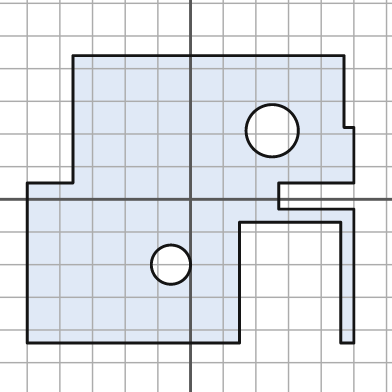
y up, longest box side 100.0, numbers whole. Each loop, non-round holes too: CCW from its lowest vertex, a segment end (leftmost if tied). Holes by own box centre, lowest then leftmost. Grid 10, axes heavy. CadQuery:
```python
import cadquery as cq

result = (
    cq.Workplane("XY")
    .moveTo(-50.0, -44.0)
    .lineTo(15.0, -44.0)
    .lineTo(15.0, -7.0)
    .lineTo(46.0, -7.0)
    .lineTo(46.0, -44.0)
    .lineTo(50.0, -44.0)
    .lineTo(50.0, -3.0)
    .lineTo(27.0, -3.0)
    .lineTo(27.0, 5.0)
    .lineTo(50.0, 5.0)
    .lineTo(50.0, 22.0)
    .lineTo(47.0, 22.0)
    .lineTo(47.0, 44.0)
    .lineTo(-36.0, 44.0)
    .lineTo(-36.0, 5.0)
    .lineTo(-50.0, 5.0)
    .close()
    .moveTo(-6.0, -20.0)
    .circle(6.0)
    .moveTo(25.0, 21.0)
    .circle(8.0)
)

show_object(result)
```